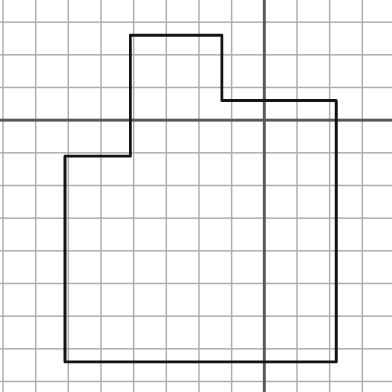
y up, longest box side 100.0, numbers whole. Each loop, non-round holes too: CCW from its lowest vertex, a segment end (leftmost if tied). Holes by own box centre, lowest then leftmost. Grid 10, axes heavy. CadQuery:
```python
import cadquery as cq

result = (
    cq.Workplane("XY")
    .moveTo(-61.0, -74.0)
    .lineTo(22.0, -74.0)
    .lineTo(22.0, 6.0)
    .lineTo(-13.0, 6.0)
    .lineTo(-13.0, 26.0)
    .lineTo(-41.0, 26.0)
    .lineTo(-41.0, -11.0)
    .lineTo(-61.0, -11.0)
    .close()
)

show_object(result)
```